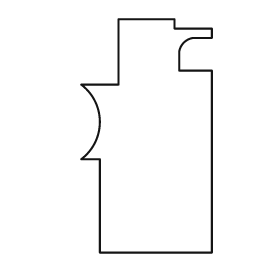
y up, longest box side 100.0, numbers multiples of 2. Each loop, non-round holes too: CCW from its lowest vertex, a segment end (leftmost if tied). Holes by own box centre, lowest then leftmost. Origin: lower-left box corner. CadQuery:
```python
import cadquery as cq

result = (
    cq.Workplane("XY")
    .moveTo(8.0, 0.0)
    .lineTo(56.0, 0.0)
    .lineTo(56.0, 78.0)
    .lineTo(42.0, 78.0)
    .lineTo(42.0, 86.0)
    .threePointArc((44.0, 90.0), (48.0, 92.0))
    .lineTo(56.0, 92.0)
    .lineTo(56.0, 96.0)
    .lineTo(40.0, 96.0)
    .lineTo(40.0, 100.0)
    .lineTo(16.0, 100.0)
    .lineTo(16.0, 72.0)
    .lineTo(0.0, 72.0)
    .threePointArc((8.0, 56.0), (0.0, 40.0))
    .lineTo(8.0, 40.0)
    .close()
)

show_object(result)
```